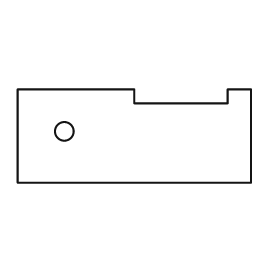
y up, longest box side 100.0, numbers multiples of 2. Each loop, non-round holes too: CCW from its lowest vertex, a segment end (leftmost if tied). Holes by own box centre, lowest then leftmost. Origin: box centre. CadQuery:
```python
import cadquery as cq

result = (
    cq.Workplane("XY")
    .moveTo(-50.0, -20.0)
    .lineTo(50.0, -20.0)
    .lineTo(50.0, 20.0)
    .lineTo(40.0, 20.0)
    .lineTo(40.0, 14.0)
    .lineTo(0.0, 14.0)
    .lineTo(0.0, 20.0)
    .lineTo(-50.0, 20.0)
    .close()
    .moveTo(-30.0, 2.0)
    .circle(4.0)
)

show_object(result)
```